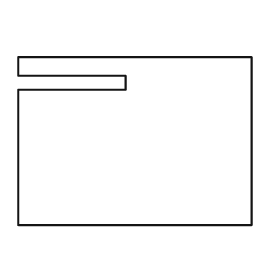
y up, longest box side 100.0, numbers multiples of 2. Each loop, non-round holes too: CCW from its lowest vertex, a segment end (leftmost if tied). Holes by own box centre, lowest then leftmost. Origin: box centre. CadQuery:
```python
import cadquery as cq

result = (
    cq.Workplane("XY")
    .moveTo(-50.0, -36.0)
    .lineTo(50.0, -36.0)
    .lineTo(50.0, 36.0)
    .lineTo(-50.0, 36.0)
    .lineTo(-50.0, 28.0)
    .lineTo(-4.0, 28.0)
    .lineTo(-4.0, 22.0)
    .lineTo(-50.0, 22.0)
    .close()
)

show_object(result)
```